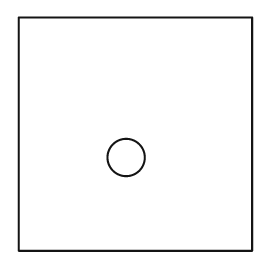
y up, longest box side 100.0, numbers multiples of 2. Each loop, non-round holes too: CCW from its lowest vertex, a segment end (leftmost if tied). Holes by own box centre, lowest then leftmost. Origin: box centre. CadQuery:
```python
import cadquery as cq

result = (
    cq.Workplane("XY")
    .moveTo(-50.0, -50.0)
    .lineTo(50.0, -50.0)
    .lineTo(50.0, 50.0)
    .lineTo(-50.0, 50.0)
    .close()
    .moveTo(-4.0, -10.0)
    .circle(8.0)
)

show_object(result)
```